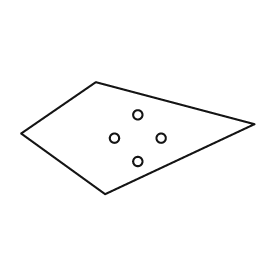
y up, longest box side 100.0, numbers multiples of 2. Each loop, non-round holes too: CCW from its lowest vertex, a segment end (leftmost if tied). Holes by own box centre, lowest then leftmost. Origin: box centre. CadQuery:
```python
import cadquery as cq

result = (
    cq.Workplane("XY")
    .moveTo(-14.0, -24.0)
    .lineTo(50.0, 6.0)
    .lineTo(-18.0, 24.0)
    .lineTo(-50.0, 2.0)
    .close()
    .moveTo(0.0, -10.0)
    .circle(2.0)
    .moveTo(-10.0, 0.0)
    .circle(2.0)
    .moveTo(10.0, 0.0)
    .circle(2.0)
    .moveTo(0.0, 10.0)
    .circle(2.0)
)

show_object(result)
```